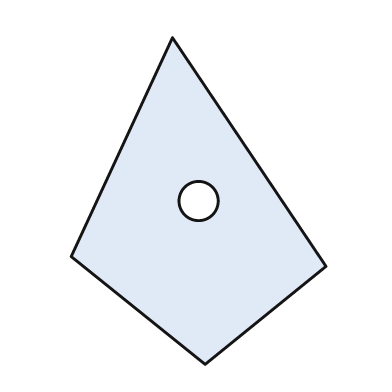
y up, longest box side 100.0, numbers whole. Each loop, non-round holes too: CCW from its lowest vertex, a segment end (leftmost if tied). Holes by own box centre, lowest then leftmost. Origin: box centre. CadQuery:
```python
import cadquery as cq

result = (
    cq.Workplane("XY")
    .moveTo(2.0, -50.0)
    .lineTo(39.0, -20.0)
    .lineTo(-8.0, 50.0)
    .lineTo(-39.0, -17.0)
    .close()
    .moveTo(0.0, 0.0)
    .circle(6.0)
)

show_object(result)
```